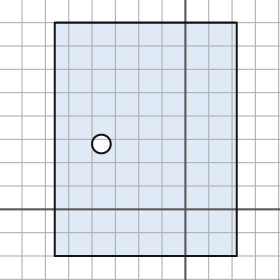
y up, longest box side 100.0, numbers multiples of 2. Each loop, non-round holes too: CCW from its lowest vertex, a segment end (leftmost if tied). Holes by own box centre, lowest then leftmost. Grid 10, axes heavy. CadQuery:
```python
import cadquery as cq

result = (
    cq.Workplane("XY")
    .moveTo(-56.0, -20.0)
    .lineTo(22.0, -20.0)
    .lineTo(22.0, 80.0)
    .lineTo(-56.0, 80.0)
    .close()
    .moveTo(-36.0, 28.0)
    .circle(4.0)
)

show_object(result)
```